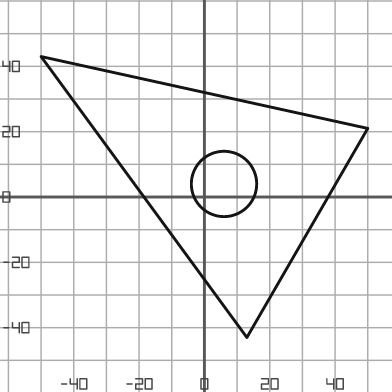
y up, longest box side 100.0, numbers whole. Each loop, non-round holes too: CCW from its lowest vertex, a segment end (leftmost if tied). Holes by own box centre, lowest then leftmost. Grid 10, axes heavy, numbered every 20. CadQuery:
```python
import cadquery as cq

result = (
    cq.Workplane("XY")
    .moveTo(13.0, -43.0)
    .lineTo(50.0, 21.0)
    .lineTo(-50.0, 43.0)
    .close()
    .moveTo(6.0, 4.0)
    .circle(10.0)
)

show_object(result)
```